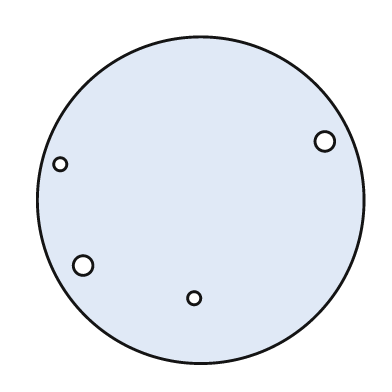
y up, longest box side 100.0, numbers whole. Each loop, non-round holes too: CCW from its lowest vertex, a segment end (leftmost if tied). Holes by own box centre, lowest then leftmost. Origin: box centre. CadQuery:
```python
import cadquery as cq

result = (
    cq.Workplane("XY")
    .moveTo(0.0, 0.0)
    .circle(50.0)
    .moveTo(-2.0, -30.0)
    .circle(2.0)
    .moveTo(-36.0, -20.0)
    .circle(3.0)
    .moveTo(-43.0, 11.0)
    .circle(2.0)
    .moveTo(38.0, 18.0)
    .circle(3.0)
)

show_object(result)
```